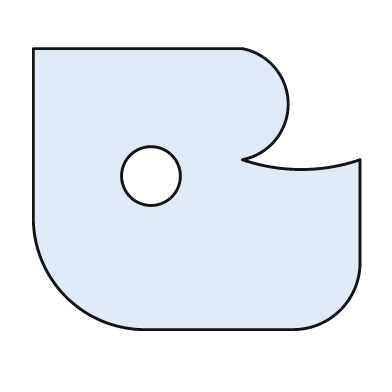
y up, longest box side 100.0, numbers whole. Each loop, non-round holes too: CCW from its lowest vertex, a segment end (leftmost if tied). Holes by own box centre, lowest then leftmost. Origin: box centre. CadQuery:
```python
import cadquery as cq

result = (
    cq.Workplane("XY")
    .moveTo(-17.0, -43.0)
    .lineTo(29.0, -43.0)
    .threePointArc((44.0, -37.0), (50.0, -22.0))
    .lineTo(50.0, 9.0)
    .threePointArc((32.0, 6.0), (14.0, 9.0))
    .threePointArc((28.0, 26.0), (14.0, 43.0))
    .lineTo(-50.0, 43.0)
    .lineTo(-50.0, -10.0)
    .threePointArc((-40.0, -33.0), (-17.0, -43.0))
    .close()
    .moveTo(-14.0, 4.0)
    .circle(9.0)
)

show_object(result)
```